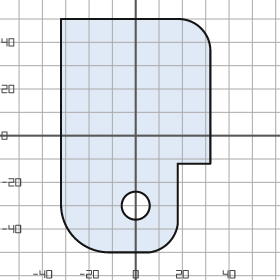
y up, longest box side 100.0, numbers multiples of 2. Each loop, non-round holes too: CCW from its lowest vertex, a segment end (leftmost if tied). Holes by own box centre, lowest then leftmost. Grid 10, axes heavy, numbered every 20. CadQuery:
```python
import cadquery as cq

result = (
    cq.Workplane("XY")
    .moveTo(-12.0, -50.0)
    .lineTo(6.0, -50.0)
    .threePointArc((14.0, -46.0), (18.0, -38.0))
    .lineTo(18.0, -12.0)
    .lineTo(32.0, -12.0)
    .lineTo(32.0, 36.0)
    .threePointArc((28.0, 46.0), (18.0, 50.0))
    .lineTo(-32.0, 50.0)
    .lineTo(-32.0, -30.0)
    .threePointArc((-26.0, -44.0), (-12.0, -50.0))
    .close()
    .moveTo(0.0, -30.0)
    .circle(6.0)
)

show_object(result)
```